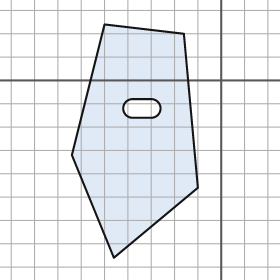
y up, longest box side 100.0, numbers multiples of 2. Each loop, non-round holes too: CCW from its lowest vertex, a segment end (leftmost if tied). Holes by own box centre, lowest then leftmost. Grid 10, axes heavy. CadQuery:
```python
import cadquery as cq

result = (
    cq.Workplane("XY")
    .moveTo(-46.0, -76.0)
    .lineTo(-10.0, -46.0)
    .lineTo(-16.0, 20.0)
    .lineTo(-50.0, 24.0)
    .lineTo(-64.0, -32.0)
    .close()
    .moveTo(-38.0, -16.0)
    .lineTo(-30.0, -16.0)
    .threePointArc((-26.0, -12.0), (-30.0, -8.0))
    .lineTo(-38.0, -8.0)
    .threePointArc((-42.0, -12.0), (-38.0, -16.0))
    .close()
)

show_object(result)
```